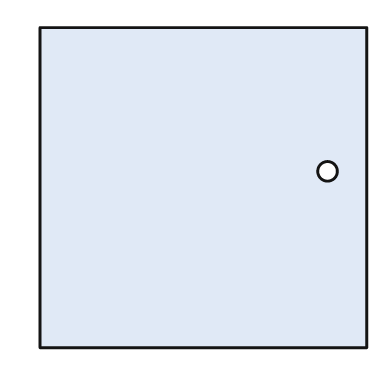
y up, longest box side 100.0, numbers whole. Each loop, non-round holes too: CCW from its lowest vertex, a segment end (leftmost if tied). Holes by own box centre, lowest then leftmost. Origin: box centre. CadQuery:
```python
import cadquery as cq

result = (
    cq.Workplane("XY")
    .moveTo(-50.0, -49.0)
    .lineTo(50.0, -49.0)
    .lineTo(50.0, 49.0)
    .lineTo(-50.0, 49.0)
    .close()
    .moveTo(38.0, 5.0)
    .circle(3.0)
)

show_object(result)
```